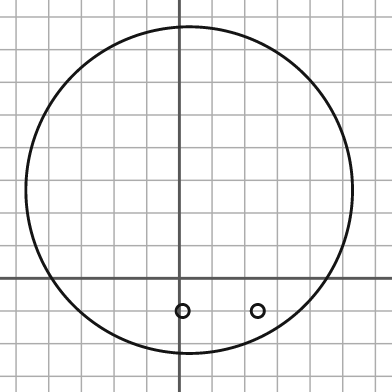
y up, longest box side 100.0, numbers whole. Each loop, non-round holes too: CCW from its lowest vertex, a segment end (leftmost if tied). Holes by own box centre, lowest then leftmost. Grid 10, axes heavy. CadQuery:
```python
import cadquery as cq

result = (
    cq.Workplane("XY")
    .moveTo(3.0, 27.0)
    .circle(50.0)
    .moveTo(1.0, -10.0)
    .circle(2.0)
    .moveTo(24.0, -10.0)
    .circle(2.0)
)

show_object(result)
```